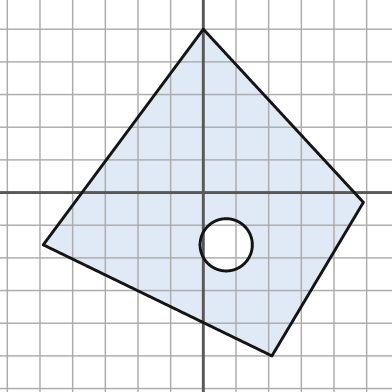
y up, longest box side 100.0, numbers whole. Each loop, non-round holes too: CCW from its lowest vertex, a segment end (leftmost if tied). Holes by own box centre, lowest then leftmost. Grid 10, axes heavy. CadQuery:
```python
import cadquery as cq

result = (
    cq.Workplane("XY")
    .moveTo(21.0, -50.0)
    .lineTo(49.0, -3.0)
    .lineTo(0.0, 50.0)
    .lineTo(-49.0, -16.0)
    .close()
    .moveTo(7.0, -16.0)
    .circle(8.0)
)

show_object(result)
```